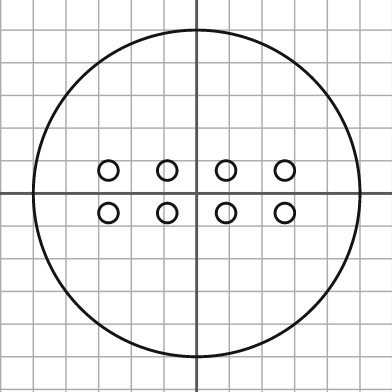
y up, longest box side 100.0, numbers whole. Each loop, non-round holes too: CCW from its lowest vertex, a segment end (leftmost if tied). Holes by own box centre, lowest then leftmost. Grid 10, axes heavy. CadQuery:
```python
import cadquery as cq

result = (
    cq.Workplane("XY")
    .moveTo(0.0, 0.0)
    .circle(50.0)
    .moveTo(-27.0, -6.0)
    .circle(3.0)
    .moveTo(-9.0, -6.0)
    .circle(3.0)
    .moveTo(9.0, -6.0)
    .circle(3.0)
    .moveTo(27.0, -6.0)
    .circle(3.0)
    .moveTo(-27.0, 7.0)
    .circle(3.0)
    .moveTo(-9.0, 7.0)
    .circle(3.0)
    .moveTo(9.0, 7.0)
    .circle(3.0)
    .moveTo(27.0, 7.0)
    .circle(3.0)
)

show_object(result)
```